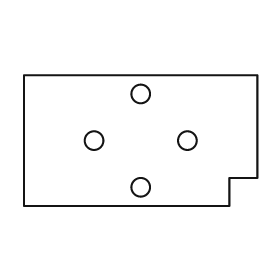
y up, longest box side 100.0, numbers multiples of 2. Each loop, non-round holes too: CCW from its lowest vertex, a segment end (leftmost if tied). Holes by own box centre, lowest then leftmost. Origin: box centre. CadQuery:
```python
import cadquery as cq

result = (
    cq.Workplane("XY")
    .moveTo(-50.0, -28.0)
    .lineTo(38.0, -28.0)
    .lineTo(38.0, -16.0)
    .lineTo(50.0, -16.0)
    .lineTo(50.0, 28.0)
    .lineTo(-50.0, 28.0)
    .close()
    .moveTo(0.0, -20.0)
    .circle(4.0)
    .moveTo(-20.0, 0.0)
    .circle(4.0)
    .moveTo(20.0, 0.0)
    .circle(4.0)
    .moveTo(0.0, 20.0)
    .circle(4.0)
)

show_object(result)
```